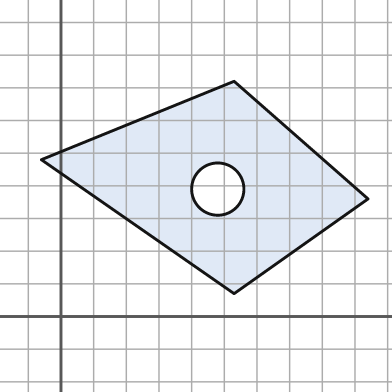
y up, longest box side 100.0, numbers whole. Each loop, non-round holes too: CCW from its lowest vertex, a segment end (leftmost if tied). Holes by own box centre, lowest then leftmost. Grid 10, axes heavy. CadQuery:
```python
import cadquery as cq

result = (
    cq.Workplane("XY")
    .moveTo(53.0, 7.0)
    .lineTo(94.0, 36.0)
    .lineTo(53.0, 72.0)
    .lineTo(-6.0, 48.0)
    .close()
    .moveTo(48.0, 39.0)
    .circle(8.0)
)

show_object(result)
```